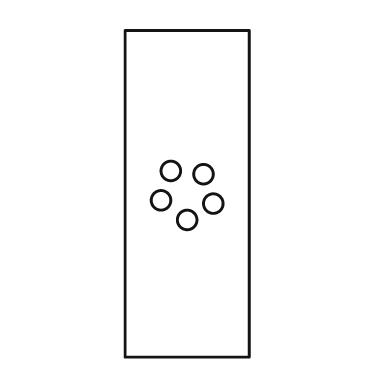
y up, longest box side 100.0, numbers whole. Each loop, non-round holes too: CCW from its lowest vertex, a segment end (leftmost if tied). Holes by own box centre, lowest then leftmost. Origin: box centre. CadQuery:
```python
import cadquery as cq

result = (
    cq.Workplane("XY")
    .moveTo(-19.0, -50.0)
    .lineTo(19.0, -50.0)
    .lineTo(19.0, 50.0)
    .lineTo(-19.0, 50.0)
    .close()
    .moveTo(0.0, -8.0)
    .circle(3.0)
    .moveTo(8.0, -3.0)
    .circle(3.0)
    .moveTo(-8.0, -2.0)
    .circle(3.0)
    .moveTo(5.0, 6.0)
    .circle(3.0)
    .moveTo(-5.0, 7.0)
    .circle(3.0)
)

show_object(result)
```